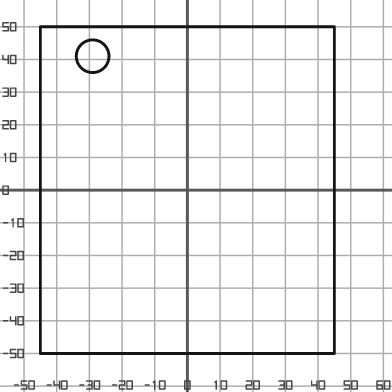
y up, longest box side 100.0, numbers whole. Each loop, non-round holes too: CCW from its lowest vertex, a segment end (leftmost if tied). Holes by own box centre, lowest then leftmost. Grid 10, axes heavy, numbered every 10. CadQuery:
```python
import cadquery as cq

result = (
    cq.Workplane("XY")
    .moveTo(-45.0, -50.0)
    .lineTo(45.0, -50.0)
    .lineTo(45.0, 50.0)
    .lineTo(-45.0, 50.0)
    .close()
    .moveTo(-29.0, 41.0)
    .circle(5.0)
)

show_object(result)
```